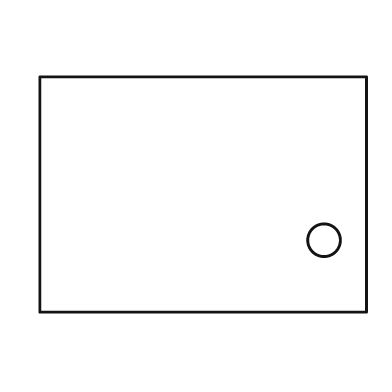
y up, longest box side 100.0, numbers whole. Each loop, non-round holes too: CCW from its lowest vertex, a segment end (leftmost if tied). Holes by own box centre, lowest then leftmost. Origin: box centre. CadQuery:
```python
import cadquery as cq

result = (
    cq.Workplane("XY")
    .moveTo(-50.0, -36.0)
    .lineTo(50.0, -36.0)
    .lineTo(50.0, 36.0)
    .lineTo(-50.0, 36.0)
    .close()
    .moveTo(37.0, -14.0)
    .circle(5.0)
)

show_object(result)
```